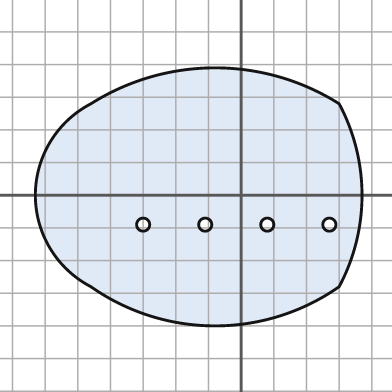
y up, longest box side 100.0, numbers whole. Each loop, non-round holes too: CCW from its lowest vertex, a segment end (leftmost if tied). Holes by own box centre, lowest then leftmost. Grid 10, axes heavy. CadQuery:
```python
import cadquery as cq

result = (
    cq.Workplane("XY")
    .moveTo(-46.0, -28.0)
    .threePointArc((-8.0, -40.0), (30.0, -28.0))
    .threePointArc((37.0, 0.0), (30.0, 28.0))
    .threePointArc((-8.0, 39.0), (-46.0, 28.0))
    .threePointArc((-63.0, 0.0), (-46.0, -28.0))
    .close()
    .moveTo(-30.0, -9.0)
    .circle(2.0)
    .moveTo(-11.0, -9.0)
    .circle(2.0)
    .moveTo(8.0, -9.0)
    .circle(2.0)
    .moveTo(27.0, -9.0)
    .circle(2.0)
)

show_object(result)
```